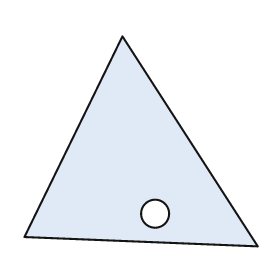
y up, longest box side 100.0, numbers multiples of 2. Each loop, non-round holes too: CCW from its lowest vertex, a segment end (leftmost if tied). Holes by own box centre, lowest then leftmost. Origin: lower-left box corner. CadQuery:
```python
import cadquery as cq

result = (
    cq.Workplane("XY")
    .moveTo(100.0, 0.0)
    .lineTo(42.0, 90.0)
    .lineTo(0.0, 4.0)
    .close()
    .moveTo(56.0, 14.0)
    .circle(6.0)
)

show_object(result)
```